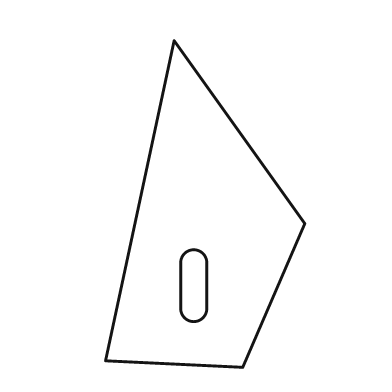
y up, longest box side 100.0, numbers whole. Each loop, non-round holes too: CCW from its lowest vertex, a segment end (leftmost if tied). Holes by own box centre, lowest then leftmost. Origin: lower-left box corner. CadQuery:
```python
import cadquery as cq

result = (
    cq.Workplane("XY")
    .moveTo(42.0, 0.0)
    .lineTo(61.0, 44.0)
    .lineTo(21.0, 100.0)
    .lineTo(0.0, 2.0)
    .close()
    .moveTo(23.0, 18.0)
    .threePointArc((27.0, 14.0), (31.0, 18.0))
    .lineTo(31.0, 32.0)
    .threePointArc((27.0, 36.0), (23.0, 32.0))
    .close()
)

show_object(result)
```